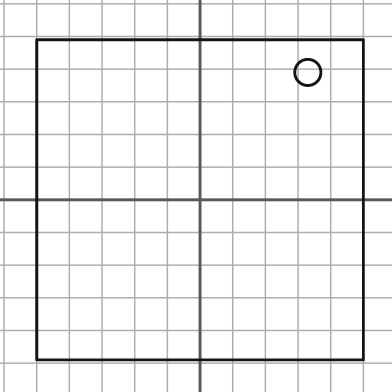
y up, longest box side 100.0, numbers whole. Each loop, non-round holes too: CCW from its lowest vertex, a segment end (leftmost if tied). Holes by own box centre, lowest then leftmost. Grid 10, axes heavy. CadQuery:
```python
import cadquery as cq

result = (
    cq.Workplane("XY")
    .moveTo(-50.0, -49.0)
    .lineTo(50.0, -49.0)
    .lineTo(50.0, 49.0)
    .lineTo(-50.0, 49.0)
    .close()
    .moveTo(33.0, 39.0)
    .circle(4.0)
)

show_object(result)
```